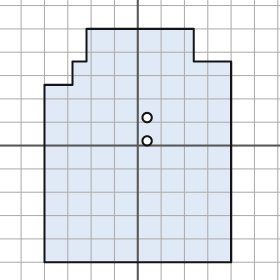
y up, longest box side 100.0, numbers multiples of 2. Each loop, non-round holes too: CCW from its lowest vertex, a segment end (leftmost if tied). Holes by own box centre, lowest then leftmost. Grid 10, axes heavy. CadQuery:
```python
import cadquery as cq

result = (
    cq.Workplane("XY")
    .moveTo(-40.0, -50.0)
    .lineTo(40.0, -50.0)
    .lineTo(40.0, 36.0)
    .lineTo(24.0, 36.0)
    .lineTo(24.0, 50.0)
    .lineTo(-22.0, 50.0)
    .lineTo(-22.0, 36.0)
    .lineTo(-28.0, 36.0)
    .lineTo(-28.0, 26.0)
    .lineTo(-40.0, 26.0)
    .close()
    .moveTo(4.0, 2.0)
    .circle(2.0)
    .moveTo(4.0, 12.0)
    .circle(2.0)
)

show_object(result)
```